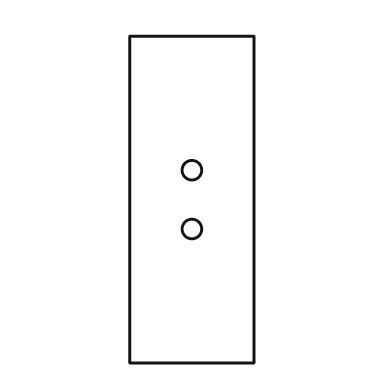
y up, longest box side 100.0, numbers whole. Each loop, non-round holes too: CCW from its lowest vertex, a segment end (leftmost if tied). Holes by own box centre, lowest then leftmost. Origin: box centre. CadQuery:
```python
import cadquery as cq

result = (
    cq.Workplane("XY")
    .moveTo(-19.0, -50.0)
    .lineTo(19.0, -50.0)
    .lineTo(19.0, 50.0)
    .lineTo(-19.0, 50.0)
    .close()
    .moveTo(0.0, -9.0)
    .circle(3.0)
    .moveTo(0.0, 9.0)
    .circle(3.0)
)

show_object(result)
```